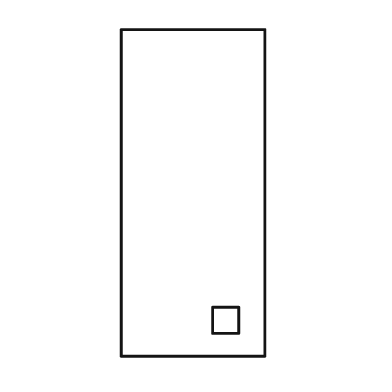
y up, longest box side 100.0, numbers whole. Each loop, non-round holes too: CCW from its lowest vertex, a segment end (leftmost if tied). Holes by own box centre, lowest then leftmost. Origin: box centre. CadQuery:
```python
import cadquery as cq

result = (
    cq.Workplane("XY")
    .moveTo(-22.0, -50.0)
    .lineTo(22.0, -50.0)
    .lineTo(22.0, 50.0)
    .lineTo(-22.0, 50.0)
    .close()
    .moveTo(6.0, -43.0)
    .lineTo(14.0, -43.0)
    .lineTo(14.0, -35.0)
    .lineTo(6.0, -35.0)
    .close()
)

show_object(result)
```